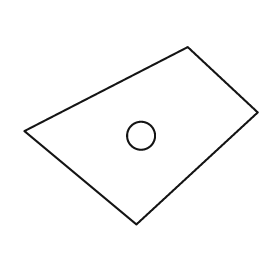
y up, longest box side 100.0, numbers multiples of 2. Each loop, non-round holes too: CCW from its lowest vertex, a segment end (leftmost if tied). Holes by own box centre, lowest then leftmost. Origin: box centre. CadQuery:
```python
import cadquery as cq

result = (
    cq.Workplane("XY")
    .moveTo(-2.0, -38.0)
    .lineTo(50.0, 10.0)
    .lineTo(20.0, 38.0)
    .lineTo(-50.0, 2.0)
    .close()
    .moveTo(0.0, 0.0)
    .circle(6.0)
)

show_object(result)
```